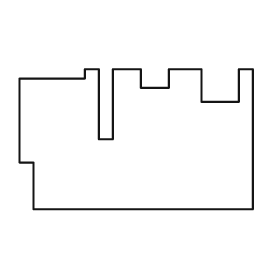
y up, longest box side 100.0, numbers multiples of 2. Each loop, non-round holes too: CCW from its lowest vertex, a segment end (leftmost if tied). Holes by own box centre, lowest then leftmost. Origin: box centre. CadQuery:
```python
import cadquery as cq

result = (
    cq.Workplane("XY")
    .moveTo(-44.0, -30.0)
    .lineTo(50.0, -30.0)
    .lineTo(50.0, 30.0)
    .lineTo(44.0, 30.0)
    .lineTo(44.0, 16.0)
    .lineTo(28.0, 16.0)
    .lineTo(28.0, 30.0)
    .lineTo(14.0, 30.0)
    .lineTo(14.0, 22.0)
    .lineTo(2.0, 22.0)
    .lineTo(2.0, 30.0)
    .lineTo(-10.0, 30.0)
    .lineTo(-10.0, 0.0)
    .lineTo(-16.0, 0.0)
    .lineTo(-16.0, 30.0)
    .lineTo(-22.0, 30.0)
    .lineTo(-22.0, 26.0)
    .lineTo(-50.0, 26.0)
    .lineTo(-50.0, -10.0)
    .lineTo(-44.0, -10.0)
    .close()
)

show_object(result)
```